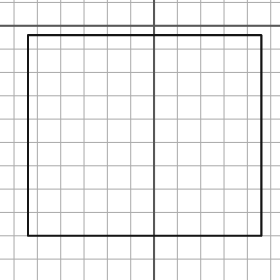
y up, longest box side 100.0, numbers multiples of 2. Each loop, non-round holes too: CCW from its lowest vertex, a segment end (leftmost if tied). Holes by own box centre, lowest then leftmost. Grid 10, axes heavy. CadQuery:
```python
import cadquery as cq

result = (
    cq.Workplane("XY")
    .moveTo(-54.0, -90.0)
    .lineTo(46.0, -90.0)
    .lineTo(46.0, -4.0)
    .lineTo(-54.0, -4.0)
    .close()
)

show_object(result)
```